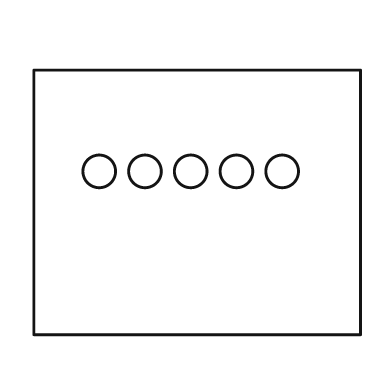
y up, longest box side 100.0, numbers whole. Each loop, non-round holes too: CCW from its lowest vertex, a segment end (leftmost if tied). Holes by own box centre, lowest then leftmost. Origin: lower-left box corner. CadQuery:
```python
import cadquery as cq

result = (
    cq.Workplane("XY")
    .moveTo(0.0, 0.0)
    .lineTo(100.0, 0.0)
    .lineTo(100.0, 81.0)
    .lineTo(0.0, 81.0)
    .close()
    .moveTo(20.0, 50.0)
    .circle(5.0)
    .moveTo(34.0, 50.0)
    .circle(5.0)
    .moveTo(48.0, 50.0)
    .circle(5.0)
    .moveTo(62.0, 50.0)
    .circle(5.0)
    .moveTo(76.0, 50.0)
    .circle(5.0)
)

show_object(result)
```